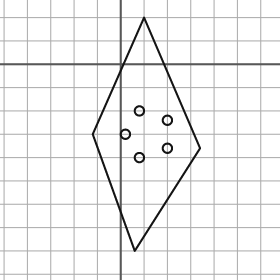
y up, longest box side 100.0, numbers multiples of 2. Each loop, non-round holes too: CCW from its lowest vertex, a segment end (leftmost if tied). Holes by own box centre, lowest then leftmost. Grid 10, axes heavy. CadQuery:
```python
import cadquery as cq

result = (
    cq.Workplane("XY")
    .moveTo(6.0, -80.0)
    .lineTo(34.0, -36.0)
    .lineTo(10.0, 20.0)
    .lineTo(-12.0, -30.0)
    .close()
    .moveTo(8.0, -40.0)
    .circle(2.0)
    .moveTo(20.0, -36.0)
    .circle(2.0)
    .moveTo(2.0, -30.0)
    .circle(2.0)
    .moveTo(20.0, -24.0)
    .circle(2.0)
    .moveTo(8.0, -20.0)
    .circle(2.0)
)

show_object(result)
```